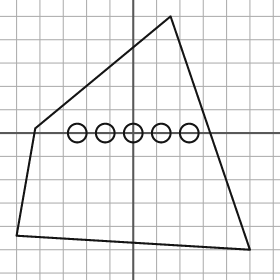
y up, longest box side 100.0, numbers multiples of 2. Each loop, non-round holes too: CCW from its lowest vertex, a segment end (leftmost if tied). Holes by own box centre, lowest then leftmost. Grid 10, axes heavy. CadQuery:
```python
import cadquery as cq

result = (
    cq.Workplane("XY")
    .moveTo(50.0, -50.0)
    .lineTo(16.0, 50.0)
    .lineTo(-42.0, 2.0)
    .lineTo(-50.0, -44.0)
    .close()
    .moveTo(-24.0, 0.0)
    .circle(4.0)
    .moveTo(-12.0, 0.0)
    .circle(4.0)
    .moveTo(0.0, 0.0)
    .circle(4.0)
    .moveTo(12.0, 0.0)
    .circle(4.0)
    .moveTo(24.0, 0.0)
    .circle(4.0)
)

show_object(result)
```